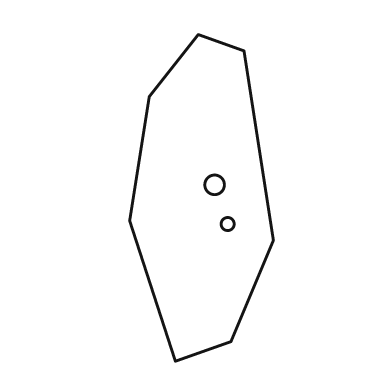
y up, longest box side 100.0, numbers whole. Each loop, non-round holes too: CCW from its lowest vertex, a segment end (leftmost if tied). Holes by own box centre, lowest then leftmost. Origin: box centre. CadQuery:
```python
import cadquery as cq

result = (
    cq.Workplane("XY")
    .moveTo(-8.0, -50.0)
    .lineTo(9.0, -44.0)
    .lineTo(22.0, -13.0)
    .lineTo(13.0, 45.0)
    .lineTo(-1.0, 50.0)
    .lineTo(-16.0, 31.0)
    .lineTo(-22.0, -7.0)
    .close()
    .moveTo(8.0, -8.0)
    .circle(2.0)
    .moveTo(4.0, 4.0)
    .circle(3.0)
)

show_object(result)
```